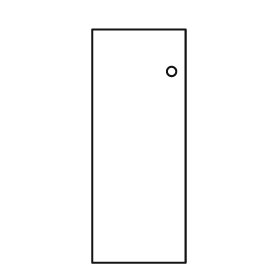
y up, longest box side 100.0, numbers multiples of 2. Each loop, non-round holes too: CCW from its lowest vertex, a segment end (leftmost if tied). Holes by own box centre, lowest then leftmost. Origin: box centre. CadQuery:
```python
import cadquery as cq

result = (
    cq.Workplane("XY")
    .moveTo(-20.0, -50.0)
    .lineTo(20.0, -50.0)
    .lineTo(20.0, 50.0)
    .lineTo(-20.0, 50.0)
    .close()
    .moveTo(14.0, 32.0)
    .circle(2.0)
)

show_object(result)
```